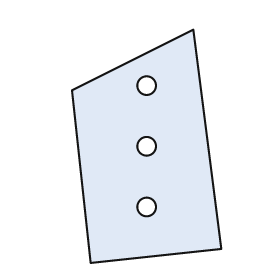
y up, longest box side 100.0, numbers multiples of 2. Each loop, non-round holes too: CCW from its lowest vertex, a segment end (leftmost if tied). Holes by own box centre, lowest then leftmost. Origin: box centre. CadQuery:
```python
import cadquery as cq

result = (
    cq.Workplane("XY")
    .moveTo(-24.0, -50.0)
    .lineTo(32.0, -44.0)
    .lineTo(20.0, 50.0)
    .lineTo(-32.0, 24.0)
    .close()
    .moveTo(0.0, -26.0)
    .circle(4.0)
    .moveTo(0.0, 0.0)
    .circle(4.0)
    .moveTo(0.0, 26.0)
    .circle(4.0)
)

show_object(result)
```